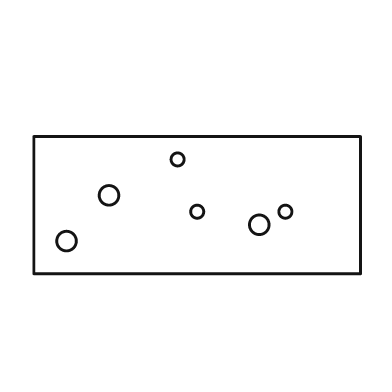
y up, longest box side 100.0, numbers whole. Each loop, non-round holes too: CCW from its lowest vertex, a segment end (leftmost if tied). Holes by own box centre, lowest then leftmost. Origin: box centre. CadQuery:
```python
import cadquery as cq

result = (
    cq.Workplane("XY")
    .moveTo(-50.0, -21.0)
    .lineTo(50.0, -21.0)
    .lineTo(50.0, 21.0)
    .lineTo(-50.0, 21.0)
    .close()
    .moveTo(-40.0, -11.0)
    .circle(3.0)
    .moveTo(19.0, -6.0)
    .circle(3.0)
    .moveTo(0.0, -2.0)
    .circle(2.0)
    .moveTo(27.0, -2.0)
    .circle(2.0)
    .moveTo(-27.0, 3.0)
    .circle(3.0)
    .moveTo(-6.0, 14.0)
    .circle(2.0)
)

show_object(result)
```